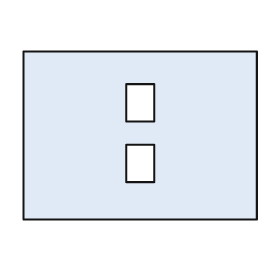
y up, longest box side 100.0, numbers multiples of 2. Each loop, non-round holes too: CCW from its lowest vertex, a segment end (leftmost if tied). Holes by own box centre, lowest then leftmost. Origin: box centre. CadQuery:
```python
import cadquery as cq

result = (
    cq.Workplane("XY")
    .moveTo(-50.0, -36.0)
    .lineTo(50.0, -36.0)
    .lineTo(50.0, 36.0)
    .lineTo(-50.0, 36.0)
    .close()
    .moveTo(-6.0, -20.0)
    .lineTo(6.0, -20.0)
    .lineTo(6.0, -4.0)
    .lineTo(-6.0, -4.0)
    .close()
    .moveTo(-6.0, 6.0)
    .lineTo(6.0, 6.0)
    .lineTo(6.0, 22.0)
    .lineTo(-6.0, 22.0)
    .close()
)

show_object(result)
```